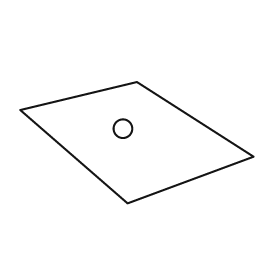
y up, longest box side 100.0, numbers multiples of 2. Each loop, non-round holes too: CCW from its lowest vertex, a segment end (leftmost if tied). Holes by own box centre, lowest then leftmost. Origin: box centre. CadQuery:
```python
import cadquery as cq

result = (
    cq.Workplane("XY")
    .moveTo(-4.0, -26.0)
    .lineTo(50.0, -6.0)
    .lineTo(0.0, 26.0)
    .lineTo(-50.0, 14.0)
    .close()
    .moveTo(-6.0, 6.0)
    .circle(4.0)
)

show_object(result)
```